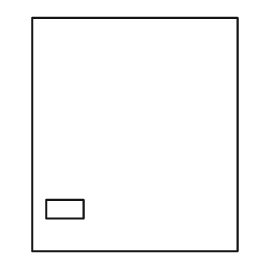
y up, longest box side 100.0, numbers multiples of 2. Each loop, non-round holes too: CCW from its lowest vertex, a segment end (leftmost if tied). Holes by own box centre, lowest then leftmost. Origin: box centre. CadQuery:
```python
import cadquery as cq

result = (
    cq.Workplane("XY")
    .moveTo(-44.0, -50.0)
    .lineTo(44.0, -50.0)
    .lineTo(44.0, 50.0)
    .lineTo(-44.0, 50.0)
    .close()
    .moveTo(-38.0, -36.0)
    .lineTo(-22.0, -36.0)
    .lineTo(-22.0, -28.0)
    .lineTo(-38.0, -28.0)
    .close()
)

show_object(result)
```